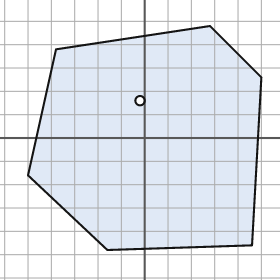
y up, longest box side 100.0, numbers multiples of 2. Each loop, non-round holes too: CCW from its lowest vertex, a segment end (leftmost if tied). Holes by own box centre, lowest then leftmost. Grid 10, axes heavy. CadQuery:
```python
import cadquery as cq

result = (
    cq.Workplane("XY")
    .moveTo(-16.0, -48.0)
    .lineTo(46.0, -46.0)
    .lineTo(50.0, 26.0)
    .lineTo(28.0, 48.0)
    .lineTo(-38.0, 38.0)
    .lineTo(-50.0, -16.0)
    .close()
    .moveTo(-2.0, 16.0)
    .circle(2.0)
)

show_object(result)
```